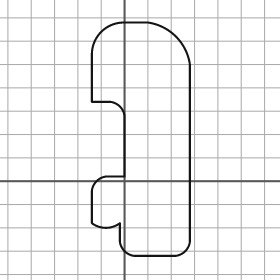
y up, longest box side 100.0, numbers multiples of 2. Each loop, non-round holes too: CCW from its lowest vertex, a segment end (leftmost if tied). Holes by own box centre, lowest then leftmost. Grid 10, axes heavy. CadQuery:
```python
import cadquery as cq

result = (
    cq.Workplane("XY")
    .moveTo(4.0, -32.0)
    .lineTo(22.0, -32.0)
    .threePointArc((26.0, -30.0), (28.0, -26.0))
    .lineTo(28.0, 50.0)
    .threePointArc((22.0, 62.0), (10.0, 68.0))
    .lineTo(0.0, 68.0)
    .threePointArc((-10.0, 64.0), (-14.0, 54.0))
    .lineTo(-14.0, 34.0)
    .lineTo(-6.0, 34.0)
    .threePointArc((-2.0, 32.0), (0.0, 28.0))
    .lineTo(0.0, 2.0)
    .lineTo(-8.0, 2.0)
    .threePointArc((-12.0, 0.0), (-14.0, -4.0))
    .lineTo(-14.0, -18.0)
    .threePointArc((-8.0, -20.0), (-2.0, -18.0))
    .lineTo(-2.0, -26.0)
    .threePointArc((0.0, -30.0), (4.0, -32.0))
    .close()
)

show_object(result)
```